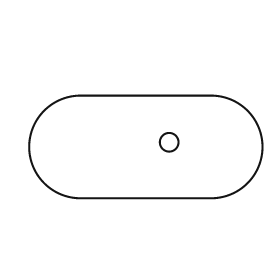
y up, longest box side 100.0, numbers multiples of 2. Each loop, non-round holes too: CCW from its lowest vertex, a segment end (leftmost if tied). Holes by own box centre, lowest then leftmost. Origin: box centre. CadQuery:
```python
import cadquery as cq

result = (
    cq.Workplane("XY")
    .moveTo(-28.0, -22.0)
    .lineTo(28.0, -22.0)
    .threePointArc((50.0, 0.0), (28.0, 22.0))
    .lineTo(-28.0, 22.0)
    .threePointArc((-50.0, 0.0), (-28.0, -22.0))
    .close()
    .moveTo(10.0, 2.0)
    .circle(4.0)
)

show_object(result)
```